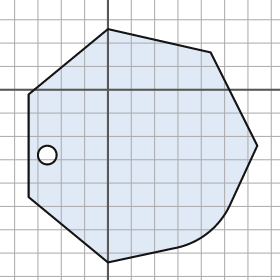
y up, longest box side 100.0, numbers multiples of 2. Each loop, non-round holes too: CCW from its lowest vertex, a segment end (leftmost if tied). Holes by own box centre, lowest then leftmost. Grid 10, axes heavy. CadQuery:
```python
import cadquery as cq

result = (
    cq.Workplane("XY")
    .moveTo(0.0, -74.0)
    .lineTo(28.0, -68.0)
    .threePointArc((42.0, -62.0), (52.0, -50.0))
    .lineTo(64.0, -24.0)
    .lineTo(44.0, 16.0)
    .lineTo(0.0, 26.0)
    .lineTo(-34.0, -2.0)
    .lineTo(-34.0, -46.0)
    .close()
    .moveTo(-26.0, -28.0)
    .circle(4.0)
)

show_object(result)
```